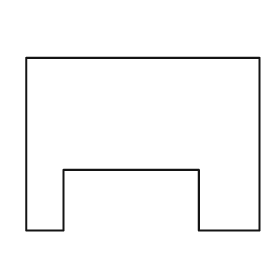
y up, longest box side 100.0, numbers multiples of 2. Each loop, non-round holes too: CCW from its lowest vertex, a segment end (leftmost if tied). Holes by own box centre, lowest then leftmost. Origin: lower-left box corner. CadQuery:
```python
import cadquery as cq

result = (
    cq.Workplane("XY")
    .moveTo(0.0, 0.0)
    .lineTo(16.0, 0.0)
    .lineTo(16.0, 26.0)
    .lineTo(74.0, 26.0)
    .lineTo(74.0, 0.0)
    .lineTo(100.0, 0.0)
    .lineTo(100.0, 74.0)
    .lineTo(0.0, 74.0)
    .close()
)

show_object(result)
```